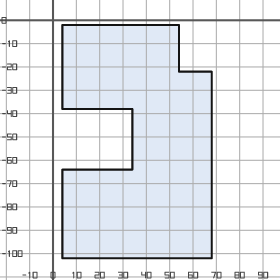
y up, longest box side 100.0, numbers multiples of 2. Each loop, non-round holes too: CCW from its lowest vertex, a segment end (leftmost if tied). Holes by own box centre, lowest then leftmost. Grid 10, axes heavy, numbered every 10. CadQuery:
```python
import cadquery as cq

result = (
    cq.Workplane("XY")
    .moveTo(4.0, -102.0)
    .lineTo(68.0, -102.0)
    .lineTo(68.0, -22.0)
    .lineTo(54.0, -22.0)
    .lineTo(54.0, -2.0)
    .lineTo(4.0, -2.0)
    .lineTo(4.0, -38.0)
    .lineTo(34.0, -38.0)
    .lineTo(34.0, -64.0)
    .lineTo(4.0, -64.0)
    .close()
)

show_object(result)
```